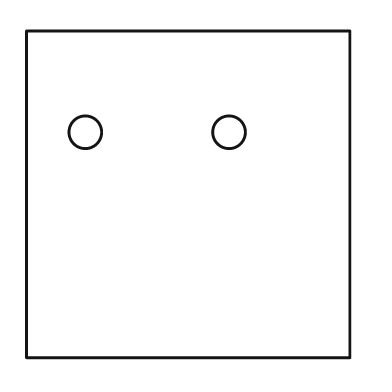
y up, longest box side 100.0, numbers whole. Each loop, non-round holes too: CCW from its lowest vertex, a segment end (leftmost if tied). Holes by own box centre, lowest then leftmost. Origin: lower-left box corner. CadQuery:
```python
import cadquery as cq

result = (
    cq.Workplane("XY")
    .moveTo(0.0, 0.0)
    .lineTo(99.0, 0.0)
    .lineTo(99.0, 100.0)
    .lineTo(0.0, 100.0)
    .close()
    .moveTo(18.0, 69.0)
    .circle(5.0)
    .moveTo(62.0, 69.0)
    .circle(5.0)
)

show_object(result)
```